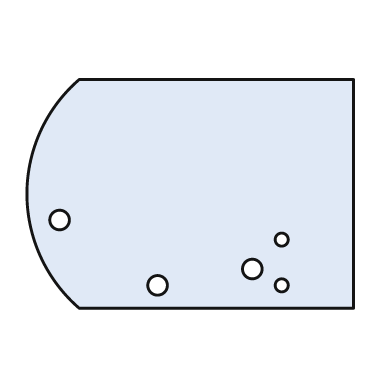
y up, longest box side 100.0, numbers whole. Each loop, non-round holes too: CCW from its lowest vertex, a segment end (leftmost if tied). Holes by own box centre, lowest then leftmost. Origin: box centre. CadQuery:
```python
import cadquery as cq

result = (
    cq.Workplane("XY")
    .moveTo(-34.0, -35.0)
    .lineTo(50.0, -35.0)
    .lineTo(50.0, 35.0)
    .lineTo(-34.0, 35.0)
    .threePointArc((-50.0, 0.0), (-34.0, -35.0))
    .close()
    .moveTo(-10.0, -28.0)
    .circle(3.0)
    .moveTo(28.0, -28.0)
    .circle(2.0)
    .moveTo(19.0, -23.0)
    .circle(3.0)
    .moveTo(28.0, -14.0)
    .circle(2.0)
    .moveTo(-40.0, -8.0)
    .circle(3.0)
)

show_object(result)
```